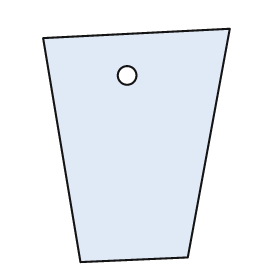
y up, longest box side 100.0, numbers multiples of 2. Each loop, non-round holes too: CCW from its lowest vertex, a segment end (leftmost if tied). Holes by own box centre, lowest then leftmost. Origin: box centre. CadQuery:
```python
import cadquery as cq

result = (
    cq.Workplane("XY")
    .moveTo(-24.0, -50.0)
    .lineTo(22.0, -48.0)
    .lineTo(40.0, 50.0)
    .lineTo(-40.0, 46.0)
    .close()
    .moveTo(-4.0, 30.0)
    .circle(4.0)
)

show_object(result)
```